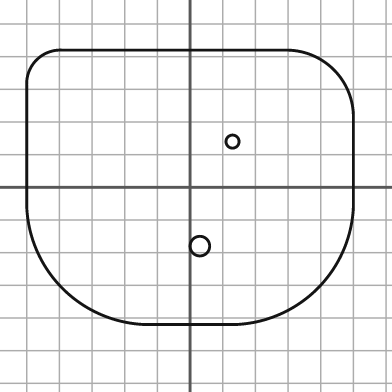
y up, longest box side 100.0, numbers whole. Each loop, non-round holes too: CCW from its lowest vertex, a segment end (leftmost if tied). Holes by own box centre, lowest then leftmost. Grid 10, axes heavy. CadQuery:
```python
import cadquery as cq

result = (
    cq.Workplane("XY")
    .moveTo(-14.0, -42.0)
    .lineTo(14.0, -42.0)
    .threePointArc((39.0, -31.0), (50.0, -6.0))
    .lineTo(50.0, 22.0)
    .threePointArc((44.0, 36.0), (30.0, 42.0))
    .lineTo(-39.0, 42.0)
    .threePointArc((-47.0, 39.0), (-50.0, 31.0))
    .lineTo(-50.0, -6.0)
    .threePointArc((-39.0, -31.0), (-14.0, -42.0))
    .close()
    .moveTo(3.0, -18.0)
    .circle(3.0)
    .moveTo(13.0, 14.0)
    .circle(2.0)
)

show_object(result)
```